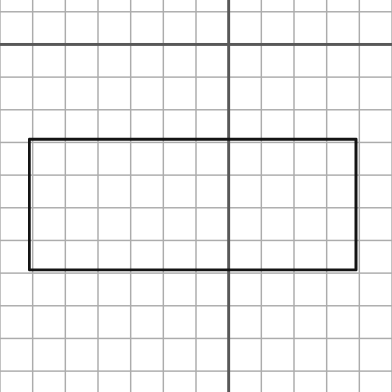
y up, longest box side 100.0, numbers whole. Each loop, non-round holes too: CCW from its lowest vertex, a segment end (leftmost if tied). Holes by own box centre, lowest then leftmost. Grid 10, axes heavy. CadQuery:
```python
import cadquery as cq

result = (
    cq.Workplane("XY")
    .moveTo(-61.0, -69.0)
    .lineTo(39.0, -69.0)
    .lineTo(39.0, -29.0)
    .lineTo(-61.0, -29.0)
    .close()
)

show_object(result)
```